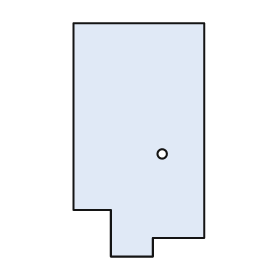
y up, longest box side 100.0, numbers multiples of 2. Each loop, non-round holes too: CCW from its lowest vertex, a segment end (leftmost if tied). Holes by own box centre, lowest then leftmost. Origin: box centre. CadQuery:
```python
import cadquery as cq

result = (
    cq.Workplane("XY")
    .moveTo(-12.0, -50.0)
    .lineTo(6.0, -50.0)
    .lineTo(6.0, -42.0)
    .lineTo(28.0, -42.0)
    .lineTo(28.0, 50.0)
    .lineTo(-28.0, 50.0)
    .lineTo(-28.0, -30.0)
    .lineTo(-12.0, -30.0)
    .close()
    .moveTo(10.0, -6.0)
    .circle(2.0)
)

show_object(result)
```